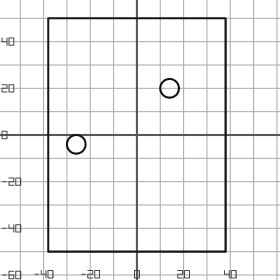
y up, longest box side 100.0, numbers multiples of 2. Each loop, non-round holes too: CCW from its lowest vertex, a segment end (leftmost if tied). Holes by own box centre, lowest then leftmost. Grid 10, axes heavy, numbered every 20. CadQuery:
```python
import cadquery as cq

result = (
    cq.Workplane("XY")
    .moveTo(-38.0, -50.0)
    .lineTo(38.0, -50.0)
    .lineTo(38.0, 50.0)
    .lineTo(-38.0, 50.0)
    .close()
    .moveTo(-26.0, -4.0)
    .circle(4.0)
    .moveTo(14.0, 20.0)
    .circle(4.0)
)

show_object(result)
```